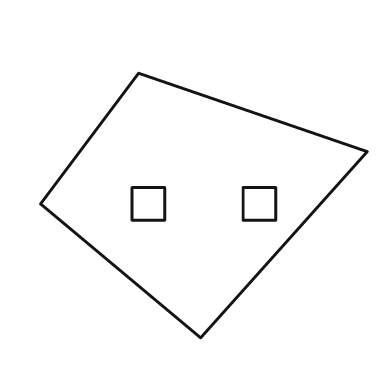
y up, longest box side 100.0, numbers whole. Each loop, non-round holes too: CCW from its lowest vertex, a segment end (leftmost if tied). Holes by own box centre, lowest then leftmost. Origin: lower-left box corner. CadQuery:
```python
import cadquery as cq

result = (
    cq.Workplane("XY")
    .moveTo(49.0, 0.0)
    .lineTo(100.0, 57.0)
    .lineTo(30.0, 81.0)
    .lineTo(0.0, 41.0)
    .close()
    .moveTo(28.0, 36.0)
    .lineTo(38.0, 36.0)
    .lineTo(38.0, 46.0)
    .lineTo(28.0, 46.0)
    .close()
    .moveTo(62.0, 36.0)
    .lineTo(72.0, 36.0)
    .lineTo(72.0, 46.0)
    .lineTo(62.0, 46.0)
    .close()
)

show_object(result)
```